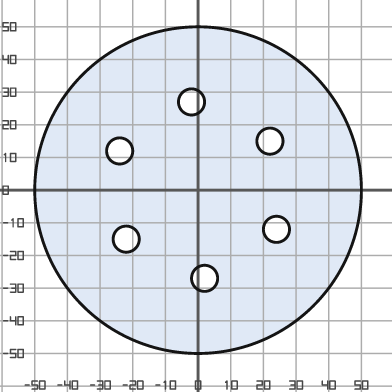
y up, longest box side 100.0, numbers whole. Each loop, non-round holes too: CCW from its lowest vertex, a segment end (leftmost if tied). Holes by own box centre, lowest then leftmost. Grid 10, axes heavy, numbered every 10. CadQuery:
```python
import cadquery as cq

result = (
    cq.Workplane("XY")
    .moveTo(0.0, 0.0)
    .circle(50.0)
    .moveTo(2.0, -27.0)
    .circle(4.0)
    .moveTo(-22.0, -15.0)
    .circle(4.0)
    .moveTo(24.0, -12.0)
    .circle(4.0)
    .moveTo(-24.0, 12.0)
    .circle(4.0)
    .moveTo(22.0, 15.0)
    .circle(4.0)
    .moveTo(-2.0, 27.0)
    .circle(4.0)
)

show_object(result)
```